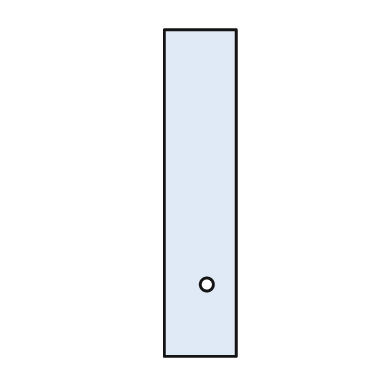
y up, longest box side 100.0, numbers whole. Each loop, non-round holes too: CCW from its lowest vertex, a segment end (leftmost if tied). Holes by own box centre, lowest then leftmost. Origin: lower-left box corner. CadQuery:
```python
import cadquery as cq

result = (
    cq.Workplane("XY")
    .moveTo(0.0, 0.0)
    .lineTo(22.0, 0.0)
    .lineTo(22.0, 100.0)
    .lineTo(0.0, 100.0)
    .close()
    .moveTo(13.0, 22.0)
    .circle(2.0)
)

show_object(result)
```